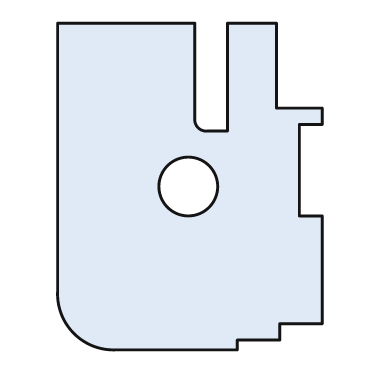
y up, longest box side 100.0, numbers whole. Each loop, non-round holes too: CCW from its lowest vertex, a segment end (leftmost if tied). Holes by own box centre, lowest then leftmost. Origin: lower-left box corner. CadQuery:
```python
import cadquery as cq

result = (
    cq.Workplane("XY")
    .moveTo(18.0, 0.0)
    .lineTo(55.0, 0.0)
    .lineTo(55.0, 3.0)
    .lineTo(68.0, 3.0)
    .lineTo(68.0, 8.0)
    .lineTo(81.0, 8.0)
    .lineTo(81.0, 41.0)
    .lineTo(74.0, 41.0)
    .lineTo(74.0, 69.0)
    .lineTo(81.0, 69.0)
    .lineTo(81.0, 74.0)
    .lineTo(67.0, 74.0)
    .lineTo(67.0, 100.0)
    .lineTo(52.0, 100.0)
    .lineTo(52.0, 67.0)
    .lineTo(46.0, 67.0)
    .threePointArc((43.0, 68.0), (42.0, 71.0))
    .lineTo(42.0, 100.0)
    .lineTo(0.0, 100.0)
    .lineTo(0.0, 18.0)
    .threePointArc((5.0, 5.0), (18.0, 0.0))
    .close()
    .moveTo(40.0, 50.0)
    .circle(9.0)
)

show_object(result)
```